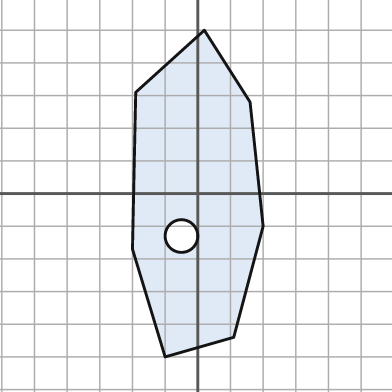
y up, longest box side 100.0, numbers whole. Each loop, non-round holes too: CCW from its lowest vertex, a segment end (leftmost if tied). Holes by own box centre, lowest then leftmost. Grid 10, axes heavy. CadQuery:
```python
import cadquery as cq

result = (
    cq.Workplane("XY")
    .moveTo(-10.0, -50.0)
    .lineTo(11.0, -44.0)
    .lineTo(20.0, -10.0)
    .lineTo(16.0, 28.0)
    .lineTo(2.0, 50.0)
    .lineTo(-19.0, 31.0)
    .lineTo(-20.0, -17.0)
    .close()
    .moveTo(-5.0, -13.0)
    .circle(5.0)
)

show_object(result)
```